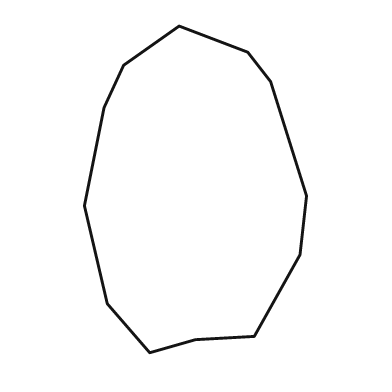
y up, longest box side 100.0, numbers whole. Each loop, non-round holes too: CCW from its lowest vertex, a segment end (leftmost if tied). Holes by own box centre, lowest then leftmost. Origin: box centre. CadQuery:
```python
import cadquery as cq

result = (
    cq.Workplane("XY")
    .moveTo(-14.0, -50.0)
    .lineTo(0.0, -46.0)
    .lineTo(18.0, -45.0)
    .lineTo(32.0, -20.0)
    .lineTo(34.0, -2.0)
    .lineTo(23.0, 33.0)
    .lineTo(16.0, 42.0)
    .lineTo(-5.0, 50.0)
    .lineTo(-22.0, 38.0)
    .lineTo(-28.0, 25.0)
    .lineTo(-34.0, -5.0)
    .lineTo(-27.0, -35.0)
    .close()
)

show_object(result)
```